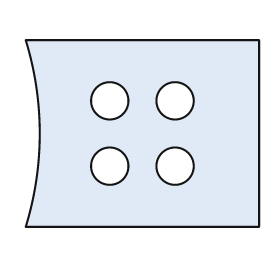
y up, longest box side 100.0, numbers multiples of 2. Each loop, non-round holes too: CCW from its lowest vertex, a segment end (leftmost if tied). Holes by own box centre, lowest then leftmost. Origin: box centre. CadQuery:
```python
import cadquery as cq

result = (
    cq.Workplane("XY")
    .moveTo(-50.0, -40.0)
    .lineTo(50.0, -40.0)
    .lineTo(50.0, 40.0)
    .lineTo(-50.0, 40.0)
    .threePointArc((-44.0, 0.0), (-50.0, -40.0))
    .close()
    .moveTo(-14.0, -14.0)
    .circle(8.0)
    .moveTo(14.0, -14.0)
    .circle(8.0)
    .moveTo(-14.0, 14.0)
    .circle(8.0)
    .moveTo(14.0, 14.0)
    .circle(8.0)
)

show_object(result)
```